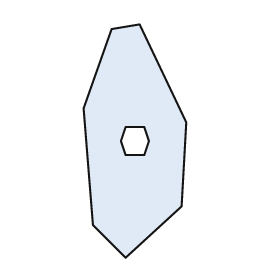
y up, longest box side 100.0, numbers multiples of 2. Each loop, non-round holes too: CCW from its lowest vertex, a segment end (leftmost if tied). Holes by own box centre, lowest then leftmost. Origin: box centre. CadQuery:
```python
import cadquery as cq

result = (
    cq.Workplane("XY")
    .moveTo(-4.0, -50.0)
    .lineTo(20.0, -28.0)
    .lineTo(22.0, 8.0)
    .lineTo(2.0, 50.0)
    .lineTo(-10.0, 48.0)
    .lineTo(-22.0, 14.0)
    .lineTo(-18.0, -36.0)
    .close()
    .moveTo(-4.0, -6.0)
    .lineTo(4.0, -6.0)
    .lineTo(6.0, 0.0)
    .lineTo(4.0, 6.0)
    .lineTo(-4.0, 6.0)
    .lineTo(-6.0, 0.0)
    .close()
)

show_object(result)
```